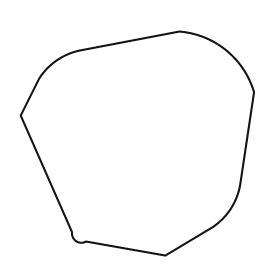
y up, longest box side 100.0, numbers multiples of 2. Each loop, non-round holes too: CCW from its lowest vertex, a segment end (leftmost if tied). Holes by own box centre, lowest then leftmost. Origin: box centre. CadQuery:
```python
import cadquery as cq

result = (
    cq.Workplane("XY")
    .moveTo(12.0, -48.0)
    .lineTo(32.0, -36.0)
    .threePointArc((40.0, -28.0), (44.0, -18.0))
    .lineTo(50.0, 22.0)
    .threePointArc((38.0, 40.0), (18.0, 48.0))
    .lineTo(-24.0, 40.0)
    .threePointArc((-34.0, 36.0), (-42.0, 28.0))
    .lineTo(-50.0, 12.0)
    .lineTo(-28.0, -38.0)
    .threePointArc((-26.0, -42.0), (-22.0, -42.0))
    .close()
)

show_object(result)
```